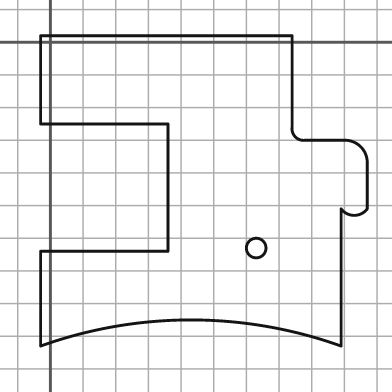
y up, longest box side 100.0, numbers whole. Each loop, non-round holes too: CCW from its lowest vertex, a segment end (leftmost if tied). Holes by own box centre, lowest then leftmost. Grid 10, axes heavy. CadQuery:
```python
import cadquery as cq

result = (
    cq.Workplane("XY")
    .moveTo(-3.0, -93.0)
    .threePointArc((43.0, -85.0), (89.0, -93.0))
    .lineTo(89.0, -51.0)
    .threePointArc((93.0, -53.0), (97.0, -51.0))
    .lineTo(97.0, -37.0)
    .threePointArc((95.0, -32.0), (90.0, -30.0))
    .lineTo(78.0, -30.0)
    .threePointArc((75.0, -29.0), (74.0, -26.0))
    .lineTo(74.0, 2.0)
    .lineTo(-3.0, 2.0)
    .lineTo(-3.0, -25.0)
    .lineTo(36.0, -25.0)
    .lineTo(36.0, -64.0)
    .lineTo(-3.0, -64.0)
    .close()
    .moveTo(63.0, -63.0)
    .circle(3.0)
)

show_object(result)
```